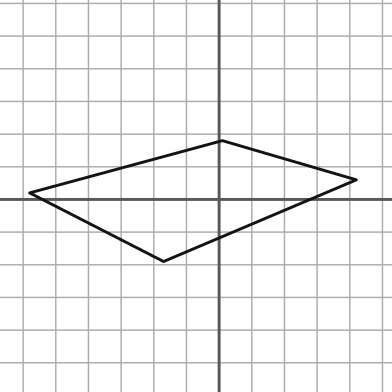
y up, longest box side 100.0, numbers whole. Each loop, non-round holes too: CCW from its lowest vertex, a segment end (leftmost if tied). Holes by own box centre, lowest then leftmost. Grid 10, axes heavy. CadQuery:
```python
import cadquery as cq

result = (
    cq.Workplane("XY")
    .moveTo(-17.0, -19.0)
    .lineTo(42.0, 6.0)
    .lineTo(1.0, 18.0)
    .lineTo(-58.0, 2.0)
    .close()
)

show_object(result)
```